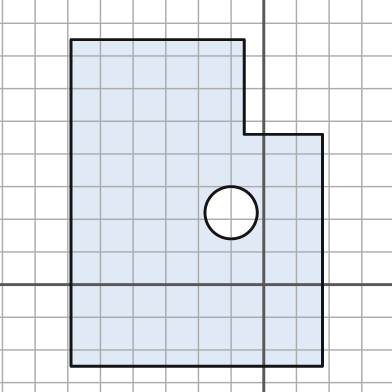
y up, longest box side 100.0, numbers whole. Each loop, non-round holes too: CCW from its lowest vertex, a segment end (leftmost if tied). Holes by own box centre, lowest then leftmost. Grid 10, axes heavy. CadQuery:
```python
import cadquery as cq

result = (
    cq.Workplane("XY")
    .moveTo(-59.0, -25.0)
    .lineTo(18.0, -25.0)
    .lineTo(18.0, 46.0)
    .lineTo(-6.0, 46.0)
    .lineTo(-6.0, 75.0)
    .lineTo(-59.0, 75.0)
    .close()
    .moveTo(-10.0, 22.0)
    .circle(8.0)
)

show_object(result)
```